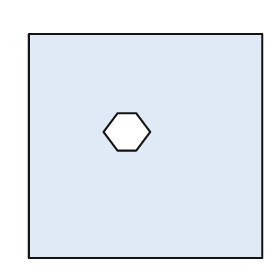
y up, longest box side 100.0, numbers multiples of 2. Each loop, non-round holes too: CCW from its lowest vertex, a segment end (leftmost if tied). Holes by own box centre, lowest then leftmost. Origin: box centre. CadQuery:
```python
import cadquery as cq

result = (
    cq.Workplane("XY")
    .moveTo(-50.0, -48.0)
    .lineTo(50.0, -48.0)
    .lineTo(50.0, 48.0)
    .lineTo(-50.0, 48.0)
    .close()
    .moveTo(-12.0, -2.0)
    .lineTo(-4.0, -2.0)
    .lineTo(2.0, 6.0)
    .lineTo(-4.0, 14.0)
    .lineTo(-12.0, 14.0)
    .lineTo(-18.0, 6.0)
    .close()
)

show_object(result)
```